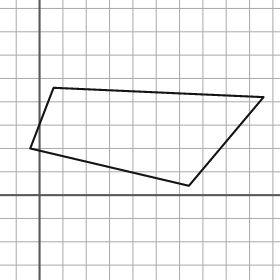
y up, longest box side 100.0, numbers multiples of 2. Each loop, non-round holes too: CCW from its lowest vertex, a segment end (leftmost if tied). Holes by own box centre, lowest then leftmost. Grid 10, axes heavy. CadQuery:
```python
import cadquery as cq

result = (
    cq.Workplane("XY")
    .moveTo(64.0, 4.0)
    .lineTo(96.0, 42.0)
    .lineTo(6.0, 46.0)
    .lineTo(-4.0, 20.0)
    .close()
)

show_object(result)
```